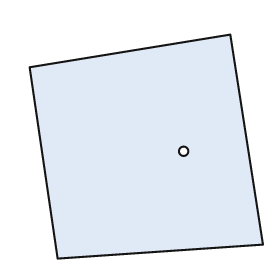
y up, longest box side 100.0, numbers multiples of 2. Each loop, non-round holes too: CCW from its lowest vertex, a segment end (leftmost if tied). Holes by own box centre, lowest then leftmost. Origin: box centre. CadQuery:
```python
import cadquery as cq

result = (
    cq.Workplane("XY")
    .moveTo(-38.0, -48.0)
    .lineTo(50.0, -42.0)
    .lineTo(36.0, 48.0)
    .lineTo(-50.0, 34.0)
    .close()
    .moveTo(16.0, -2.0)
    .circle(2.0)
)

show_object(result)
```